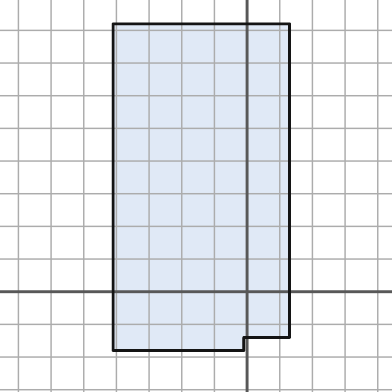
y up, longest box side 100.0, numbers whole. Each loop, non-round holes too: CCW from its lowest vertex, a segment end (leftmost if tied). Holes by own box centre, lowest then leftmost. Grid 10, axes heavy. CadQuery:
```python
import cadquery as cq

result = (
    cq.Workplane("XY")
    .moveTo(-41.0, -18.0)
    .lineTo(-1.0, -18.0)
    .lineTo(-1.0, -14.0)
    .lineTo(13.0, -14.0)
    .lineTo(13.0, 82.0)
    .lineTo(-41.0, 82.0)
    .close()
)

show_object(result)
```